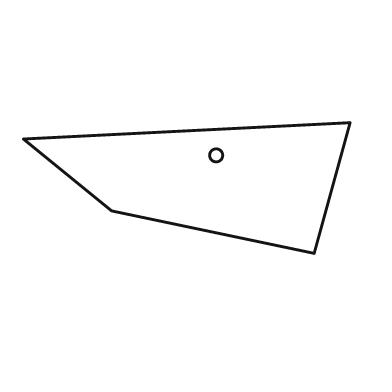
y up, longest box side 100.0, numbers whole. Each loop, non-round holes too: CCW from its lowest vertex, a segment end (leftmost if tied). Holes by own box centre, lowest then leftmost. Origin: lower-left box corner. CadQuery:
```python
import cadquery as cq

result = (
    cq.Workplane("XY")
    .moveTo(89.0, 0.0)
    .lineTo(100.0, 40.0)
    .lineTo(0.0, 35.0)
    .lineTo(27.0, 13.0)
    .close()
    .moveTo(59.0, 30.0)
    .circle(2.0)
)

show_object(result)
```